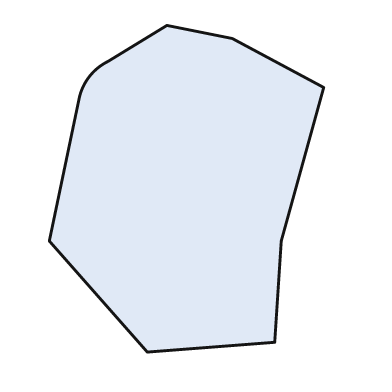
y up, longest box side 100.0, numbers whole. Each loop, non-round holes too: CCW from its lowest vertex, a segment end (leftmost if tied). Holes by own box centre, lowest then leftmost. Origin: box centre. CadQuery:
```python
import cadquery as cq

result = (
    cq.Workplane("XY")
    .moveTo(-12.0, -50.0)
    .lineTo(27.0, -47.0)
    .lineTo(29.0, -16.0)
    .lineTo(42.0, 31.0)
    .lineTo(14.0, 46.0)
    .lineTo(-6.0, 50.0)
    .lineTo(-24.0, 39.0)
    .threePointArc((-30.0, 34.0), (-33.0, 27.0))
    .lineTo(-42.0, -16.0)
    .close()
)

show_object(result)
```